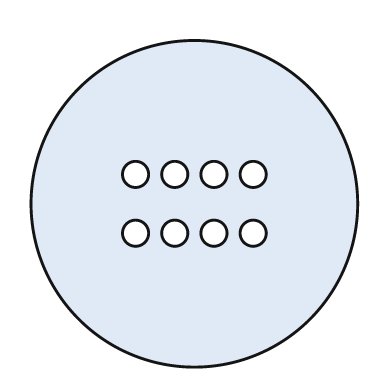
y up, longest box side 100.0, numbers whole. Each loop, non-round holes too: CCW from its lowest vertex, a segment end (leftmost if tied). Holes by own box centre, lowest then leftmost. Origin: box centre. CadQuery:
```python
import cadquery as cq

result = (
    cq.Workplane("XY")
    .moveTo(0.0, 0.0)
    .circle(50.0)
    .moveTo(-18.0, -9.0)
    .circle(4.0)
    .moveTo(-6.0, -9.0)
    .circle(4.0)
    .moveTo(6.0, -9.0)
    .circle(4.0)
    .moveTo(18.0, -9.0)
    .circle(4.0)
    .moveTo(-18.0, 9.0)
    .circle(4.0)
    .moveTo(-6.0, 9.0)
    .circle(4.0)
    .moveTo(6.0, 9.0)
    .circle(4.0)
    .moveTo(18.0, 9.0)
    .circle(4.0)
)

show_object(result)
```